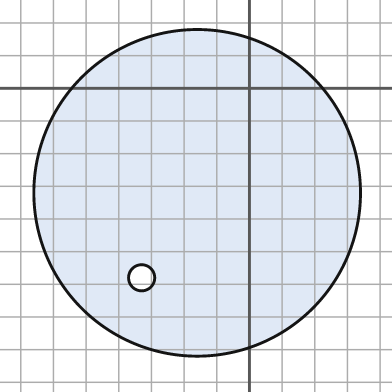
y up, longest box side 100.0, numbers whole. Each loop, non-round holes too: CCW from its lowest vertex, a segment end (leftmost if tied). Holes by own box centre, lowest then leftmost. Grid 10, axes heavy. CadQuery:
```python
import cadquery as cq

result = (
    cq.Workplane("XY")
    .moveTo(-16.0, -32.0)
    .circle(50.0)
    .moveTo(-33.0, -58.0)
    .circle(4.0)
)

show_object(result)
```